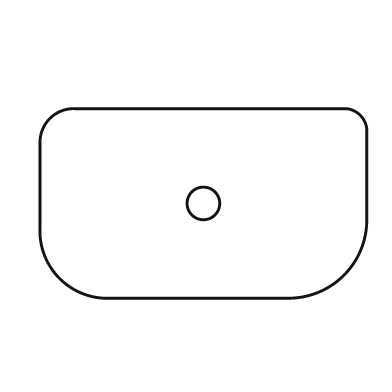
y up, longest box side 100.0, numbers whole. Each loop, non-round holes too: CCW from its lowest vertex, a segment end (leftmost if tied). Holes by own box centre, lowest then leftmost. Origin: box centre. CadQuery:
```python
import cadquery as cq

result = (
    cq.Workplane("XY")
    .moveTo(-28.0, -29.0)
    .lineTo(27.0, -29.0)
    .threePointArc((43.0, -22.0), (50.0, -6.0))
    .lineTo(50.0, 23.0)
    .threePointArc((48.0, 27.0), (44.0, 29.0))
    .lineTo(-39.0, 29.0)
    .threePointArc((-47.0, 26.0), (-50.0, 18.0))
    .lineTo(-50.0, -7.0)
    .threePointArc((-44.0, -23.0), (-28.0, -29.0))
    .close()
    .moveTo(0.0, 0.0)
    .circle(5.0)
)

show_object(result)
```